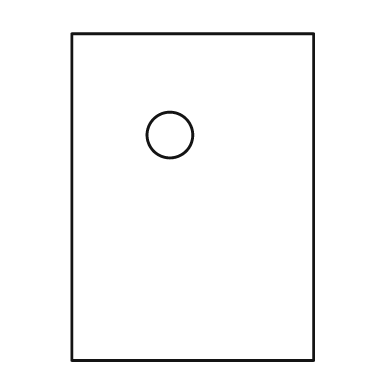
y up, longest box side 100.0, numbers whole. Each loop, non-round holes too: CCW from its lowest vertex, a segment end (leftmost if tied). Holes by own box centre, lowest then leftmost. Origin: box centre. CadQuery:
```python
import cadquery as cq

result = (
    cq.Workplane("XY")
    .moveTo(-37.0, -50.0)
    .lineTo(37.0, -50.0)
    .lineTo(37.0, 50.0)
    .lineTo(-37.0, 50.0)
    .close()
    .moveTo(-7.0, 19.0)
    .circle(7.0)
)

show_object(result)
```